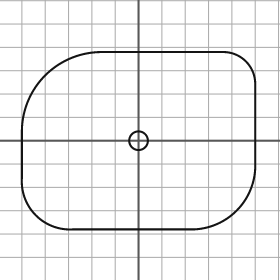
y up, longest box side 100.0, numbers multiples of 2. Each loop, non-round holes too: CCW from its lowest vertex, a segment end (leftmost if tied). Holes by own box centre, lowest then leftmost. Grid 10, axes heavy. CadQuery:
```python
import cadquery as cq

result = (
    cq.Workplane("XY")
    .moveTo(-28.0, -38.0)
    .lineTo(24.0, -38.0)
    .threePointArc((42.0, -30.0), (50.0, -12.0))
    .lineTo(50.0, 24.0)
    .threePointArc((46.0, 34.0), (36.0, 38.0))
    .lineTo(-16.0, 38.0)
    .threePointArc((-40.0, 28.0), (-50.0, 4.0))
    .lineTo(-50.0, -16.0)
    .threePointArc((-44.0, -32.0), (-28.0, -38.0))
    .close()
    .moveTo(0.0, 0.0)
    .circle(4.0)
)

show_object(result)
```